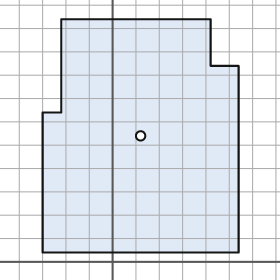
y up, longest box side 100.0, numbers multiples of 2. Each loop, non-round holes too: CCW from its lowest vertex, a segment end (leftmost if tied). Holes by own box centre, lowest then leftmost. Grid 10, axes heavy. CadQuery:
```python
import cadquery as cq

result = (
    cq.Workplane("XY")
    .moveTo(-30.0, 4.0)
    .lineTo(54.0, 4.0)
    .lineTo(54.0, 84.0)
    .lineTo(42.0, 84.0)
    .lineTo(42.0, 104.0)
    .lineTo(-22.0, 104.0)
    .lineTo(-22.0, 64.0)
    .lineTo(-30.0, 64.0)
    .close()
    .moveTo(12.0, 54.0)
    .circle(2.0)
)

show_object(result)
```